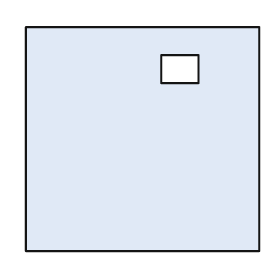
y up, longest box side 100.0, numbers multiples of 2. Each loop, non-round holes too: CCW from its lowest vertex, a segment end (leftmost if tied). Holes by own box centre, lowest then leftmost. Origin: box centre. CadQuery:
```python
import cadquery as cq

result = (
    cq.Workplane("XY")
    .moveTo(-50.0, -48.0)
    .lineTo(50.0, -48.0)
    .lineTo(50.0, 48.0)
    .lineTo(-50.0, 48.0)
    .close()
    .moveTo(8.0, 24.0)
    .lineTo(24.0, 24.0)
    .lineTo(24.0, 36.0)
    .lineTo(8.0, 36.0)
    .close()
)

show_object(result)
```